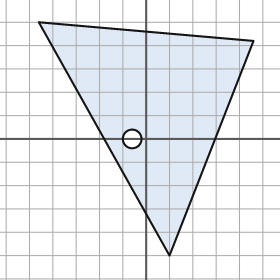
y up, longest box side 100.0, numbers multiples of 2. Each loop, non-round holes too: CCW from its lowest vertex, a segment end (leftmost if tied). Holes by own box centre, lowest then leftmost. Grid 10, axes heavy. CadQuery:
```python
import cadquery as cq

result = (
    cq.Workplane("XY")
    .moveTo(10.0, -50.0)
    .lineTo(46.0, 42.0)
    .lineTo(-46.0, 50.0)
    .close()
    .moveTo(-6.0, 0.0)
    .circle(4.0)
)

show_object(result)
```